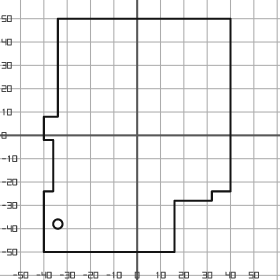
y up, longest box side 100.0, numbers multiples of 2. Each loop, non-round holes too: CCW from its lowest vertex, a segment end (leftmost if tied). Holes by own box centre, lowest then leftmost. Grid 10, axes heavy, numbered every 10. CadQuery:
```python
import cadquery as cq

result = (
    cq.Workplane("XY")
    .moveTo(-40.0, -50.0)
    .lineTo(16.0, -50.0)
    .lineTo(16.0, -28.0)
    .lineTo(32.0, -28.0)
    .lineTo(32.0, -24.0)
    .lineTo(40.0, -24.0)
    .lineTo(40.0, 50.0)
    .lineTo(-34.0, 50.0)
    .lineTo(-34.0, 8.0)
    .lineTo(-40.0, 8.0)
    .lineTo(-40.0, -2.0)
    .lineTo(-36.0, -2.0)
    .lineTo(-36.0, -24.0)
    .lineTo(-40.0, -24.0)
    .close()
    .moveTo(-34.0, -38.0)
    .circle(2.0)
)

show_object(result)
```